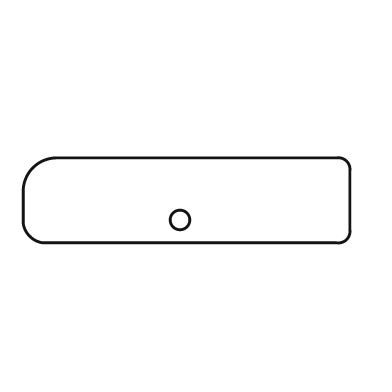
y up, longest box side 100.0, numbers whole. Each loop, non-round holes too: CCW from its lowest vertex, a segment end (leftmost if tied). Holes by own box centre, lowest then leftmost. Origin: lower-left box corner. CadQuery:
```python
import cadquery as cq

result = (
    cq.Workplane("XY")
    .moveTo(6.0, 0.0)
    .lineTo(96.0, 0.0)
    .threePointArc((99.0, 1.0), (100.0, 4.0))
    .lineTo(100.0, 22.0)
    .threePointArc((99.0, 25.0), (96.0, 26.0))
    .lineTo(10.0, 26.0)
    .threePointArc((3.0, 23.0), (0.0, 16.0))
    .lineTo(0.0, 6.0)
    .threePointArc((2.0, 2.0), (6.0, 0.0))
    .close()
    .moveTo(48.0, 7.0)
    .circle(3.0)
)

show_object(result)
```